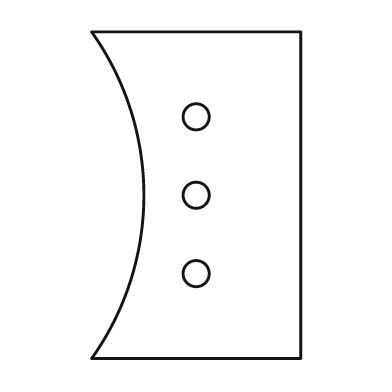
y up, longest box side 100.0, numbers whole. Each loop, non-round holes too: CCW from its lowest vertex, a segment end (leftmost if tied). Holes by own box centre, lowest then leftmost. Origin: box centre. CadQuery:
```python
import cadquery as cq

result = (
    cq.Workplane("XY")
    .moveTo(-32.0, -50.0)
    .lineTo(32.0, -50.0)
    .lineTo(32.0, 50.0)
    .lineTo(-32.0, 50.0)
    .threePointArc((-16.0, 0.0), (-32.0, -50.0))
    .close()
    .moveTo(0.0, -24.0)
    .circle(4.0)
    .moveTo(0.0, 0.0)
    .circle(4.0)
    .moveTo(0.0, 24.0)
    .circle(4.0)
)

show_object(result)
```